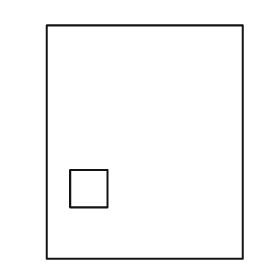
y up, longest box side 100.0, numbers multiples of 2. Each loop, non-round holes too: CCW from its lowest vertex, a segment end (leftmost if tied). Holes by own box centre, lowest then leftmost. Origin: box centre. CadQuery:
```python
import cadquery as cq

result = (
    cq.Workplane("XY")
    .moveTo(-42.0, -50.0)
    .lineTo(42.0, -50.0)
    .lineTo(42.0, 50.0)
    .lineTo(-42.0, 50.0)
    .close()
    .moveTo(-32.0, -28.0)
    .lineTo(-16.0, -28.0)
    .lineTo(-16.0, -12.0)
    .lineTo(-32.0, -12.0)
    .close()
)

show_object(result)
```